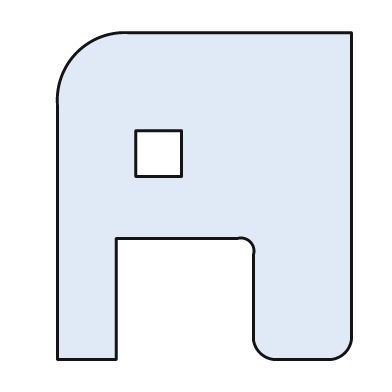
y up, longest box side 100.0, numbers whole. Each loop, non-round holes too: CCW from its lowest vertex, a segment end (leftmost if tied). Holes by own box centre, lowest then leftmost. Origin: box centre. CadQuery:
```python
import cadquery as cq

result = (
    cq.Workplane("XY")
    .moveTo(-45.0, -50.0)
    .lineTo(-27.0, -50.0)
    .lineTo(-27.0, -13.0)
    .lineTo(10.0, -13.0)
    .threePointArc((14.0, -14.0), (15.0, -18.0))
    .lineTo(15.0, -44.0)
    .threePointArc((17.0, -48.0), (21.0, -50.0))
    .lineTo(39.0, -50.0)
    .threePointArc((43.0, -48.0), (45.0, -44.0))
    .lineTo(45.0, 50.0)
    .lineTo(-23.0, 50.0)
    .threePointArc((-39.0, 44.0), (-45.0, 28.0))
    .close()
    .moveTo(-21.0, 6.0)
    .lineTo(-7.0, 6.0)
    .lineTo(-7.0, 20.0)
    .lineTo(-21.0, 20.0)
    .close()
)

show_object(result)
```